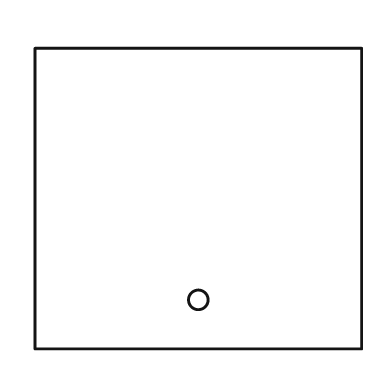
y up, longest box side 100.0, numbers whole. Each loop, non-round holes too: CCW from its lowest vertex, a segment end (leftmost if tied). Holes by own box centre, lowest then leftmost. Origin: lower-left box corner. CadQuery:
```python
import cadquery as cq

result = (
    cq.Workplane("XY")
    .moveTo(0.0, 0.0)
    .lineTo(100.0, 0.0)
    .lineTo(100.0, 92.0)
    .lineTo(0.0, 92.0)
    .close()
    .moveTo(50.0, 15.0)
    .circle(3.0)
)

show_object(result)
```